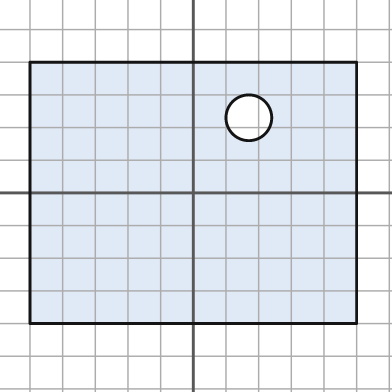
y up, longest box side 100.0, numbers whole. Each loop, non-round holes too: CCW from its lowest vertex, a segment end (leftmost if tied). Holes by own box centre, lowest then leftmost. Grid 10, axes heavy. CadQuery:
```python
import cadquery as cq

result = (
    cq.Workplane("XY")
    .moveTo(-50.0, -40.0)
    .lineTo(50.0, -40.0)
    .lineTo(50.0, 40.0)
    .lineTo(-50.0, 40.0)
    .close()
    .moveTo(17.0, 23.0)
    .circle(7.0)
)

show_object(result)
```